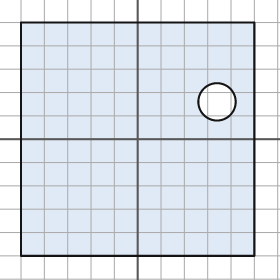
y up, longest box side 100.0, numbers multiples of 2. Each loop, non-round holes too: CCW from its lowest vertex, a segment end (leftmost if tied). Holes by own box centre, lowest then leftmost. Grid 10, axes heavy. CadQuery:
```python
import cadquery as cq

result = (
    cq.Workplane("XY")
    .moveTo(-50.0, -50.0)
    .lineTo(50.0, -50.0)
    .lineTo(50.0, 50.0)
    .lineTo(-50.0, 50.0)
    .close()
    .moveTo(34.0, 16.0)
    .circle(8.0)
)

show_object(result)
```